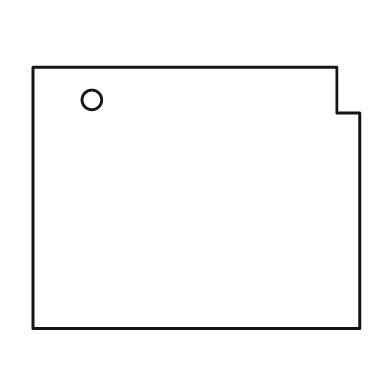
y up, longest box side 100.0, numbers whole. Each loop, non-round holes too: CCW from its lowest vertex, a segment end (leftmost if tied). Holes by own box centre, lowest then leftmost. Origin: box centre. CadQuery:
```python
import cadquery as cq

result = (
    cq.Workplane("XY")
    .moveTo(-50.0, -40.0)
    .lineTo(50.0, -40.0)
    .lineTo(50.0, 26.0)
    .lineTo(43.0, 26.0)
    .lineTo(43.0, 40.0)
    .lineTo(-50.0, 40.0)
    .close()
    .moveTo(-32.0, 30.0)
    .circle(3.0)
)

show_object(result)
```